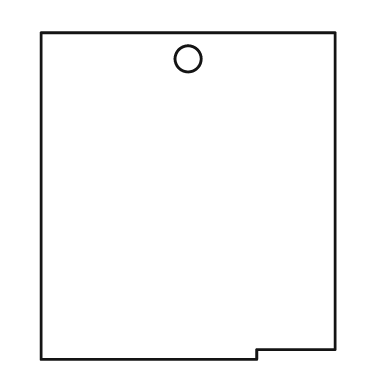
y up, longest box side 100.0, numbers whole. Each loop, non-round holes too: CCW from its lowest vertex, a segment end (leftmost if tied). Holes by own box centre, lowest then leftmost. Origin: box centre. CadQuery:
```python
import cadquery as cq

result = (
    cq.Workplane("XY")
    .moveTo(-45.0, -50.0)
    .lineTo(21.0, -50.0)
    .lineTo(21.0, -47.0)
    .lineTo(45.0, -47.0)
    .lineTo(45.0, 50.0)
    .lineTo(-45.0, 50.0)
    .close()
    .moveTo(0.0, 42.0)
    .circle(4.0)
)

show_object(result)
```